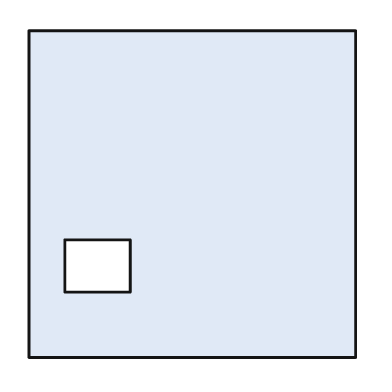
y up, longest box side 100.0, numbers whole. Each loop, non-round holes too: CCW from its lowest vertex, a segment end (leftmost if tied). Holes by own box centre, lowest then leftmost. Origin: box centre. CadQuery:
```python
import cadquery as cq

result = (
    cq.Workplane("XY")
    .moveTo(-50.0, -50.0)
    .lineTo(50.0, -50.0)
    .lineTo(50.0, 50.0)
    .lineTo(-50.0, 50.0)
    .close()
    .moveTo(-39.0, -30.0)
    .lineTo(-19.0, -30.0)
    .lineTo(-19.0, -14.0)
    .lineTo(-39.0, -14.0)
    .close()
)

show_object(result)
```